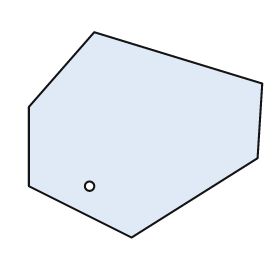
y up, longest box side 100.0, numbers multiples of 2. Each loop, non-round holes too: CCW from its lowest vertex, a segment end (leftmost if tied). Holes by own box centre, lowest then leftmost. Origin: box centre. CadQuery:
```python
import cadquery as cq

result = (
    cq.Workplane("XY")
    .moveTo(-6.0, -44.0)
    .lineTo(48.0, -10.0)
    .lineTo(50.0, 22.0)
    .lineTo(-22.0, 44.0)
    .lineTo(-50.0, 12.0)
    .lineTo(-50.0, -22.0)
    .close()
    .moveTo(-24.0, -22.0)
    .circle(2.0)
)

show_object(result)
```